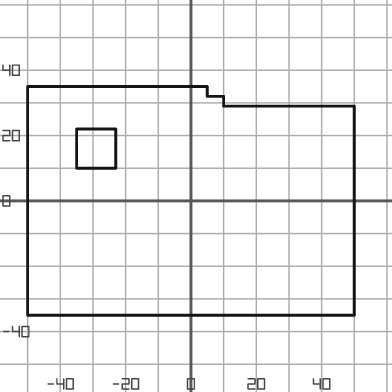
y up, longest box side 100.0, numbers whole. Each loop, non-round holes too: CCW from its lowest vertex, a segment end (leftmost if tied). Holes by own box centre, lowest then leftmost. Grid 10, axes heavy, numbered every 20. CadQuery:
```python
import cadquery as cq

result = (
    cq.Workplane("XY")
    .moveTo(-50.0, -35.0)
    .lineTo(50.0, -35.0)
    .lineTo(50.0, 29.0)
    .lineTo(10.0, 29.0)
    .lineTo(10.0, 32.0)
    .lineTo(5.0, 32.0)
    .lineTo(5.0, 35.0)
    .lineTo(-50.0, 35.0)
    .close()
    .moveTo(-35.0, 10.0)
    .lineTo(-23.0, 10.0)
    .lineTo(-23.0, 22.0)
    .lineTo(-35.0, 22.0)
    .close()
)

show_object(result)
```